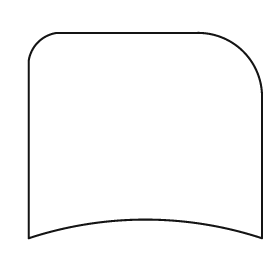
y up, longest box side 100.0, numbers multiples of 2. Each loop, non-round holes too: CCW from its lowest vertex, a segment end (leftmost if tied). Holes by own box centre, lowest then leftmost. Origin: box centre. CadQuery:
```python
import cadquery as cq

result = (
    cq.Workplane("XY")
    .moveTo(-50.0, -44.0)
    .threePointArc((0.0, -36.0), (50.0, -44.0))
    .lineTo(50.0, 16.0)
    .threePointArc((42.0, 36.0), (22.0, 44.0))
    .lineTo(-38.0, 44.0)
    .threePointArc((-46.0, 40.0), (-50.0, 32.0))
    .close()
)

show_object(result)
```